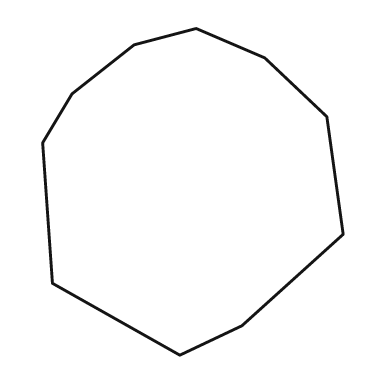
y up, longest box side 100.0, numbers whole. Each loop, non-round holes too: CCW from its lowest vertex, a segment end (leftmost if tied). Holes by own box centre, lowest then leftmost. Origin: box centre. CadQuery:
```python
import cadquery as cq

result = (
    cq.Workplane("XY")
    .moveTo(-4.0, -50.0)
    .lineTo(15.0, -41.0)
    .lineTo(46.0, -13.0)
    .lineTo(41.0, 23.0)
    .lineTo(22.0, 41.0)
    .lineTo(1.0, 50.0)
    .lineTo(-18.0, 45.0)
    .lineTo(-37.0, 30.0)
    .lineTo(-46.0, 15.0)
    .lineTo(-43.0, -28.0)
    .close()
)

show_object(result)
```